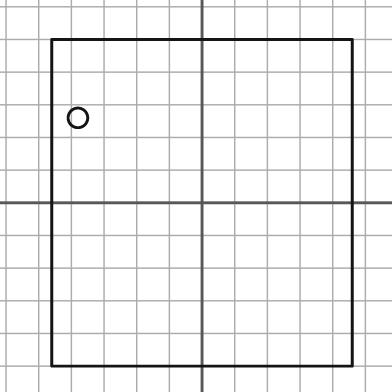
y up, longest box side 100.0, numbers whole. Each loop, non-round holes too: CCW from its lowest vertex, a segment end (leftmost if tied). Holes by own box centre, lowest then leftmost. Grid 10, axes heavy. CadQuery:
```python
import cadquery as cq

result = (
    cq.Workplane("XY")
    .moveTo(-46.0, -50.0)
    .lineTo(46.0, -50.0)
    .lineTo(46.0, 50.0)
    .lineTo(-46.0, 50.0)
    .close()
    .moveTo(-38.0, 26.0)
    .circle(3.0)
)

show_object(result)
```